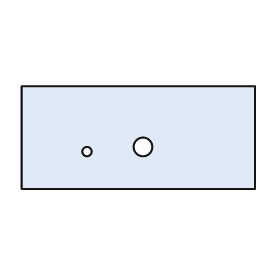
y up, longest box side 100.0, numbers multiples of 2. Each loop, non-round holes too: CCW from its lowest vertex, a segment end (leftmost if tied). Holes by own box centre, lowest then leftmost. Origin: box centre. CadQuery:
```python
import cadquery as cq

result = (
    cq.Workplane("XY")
    .moveTo(-50.0, -22.0)
    .lineTo(50.0, -22.0)
    .lineTo(50.0, 22.0)
    .lineTo(-50.0, 22.0)
    .close()
    .moveTo(-22.0, -6.0)
    .circle(2.0)
    .moveTo(2.0, -4.0)
    .circle(4.0)
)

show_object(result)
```